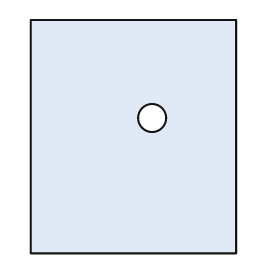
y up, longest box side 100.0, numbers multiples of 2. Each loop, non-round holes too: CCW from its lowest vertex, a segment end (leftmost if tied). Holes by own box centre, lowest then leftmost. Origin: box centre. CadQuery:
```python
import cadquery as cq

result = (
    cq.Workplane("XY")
    .moveTo(-44.0, -50.0)
    .lineTo(44.0, -50.0)
    .lineTo(44.0, 50.0)
    .lineTo(-44.0, 50.0)
    .close()
    .moveTo(8.0, 8.0)
    .circle(6.0)
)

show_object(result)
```